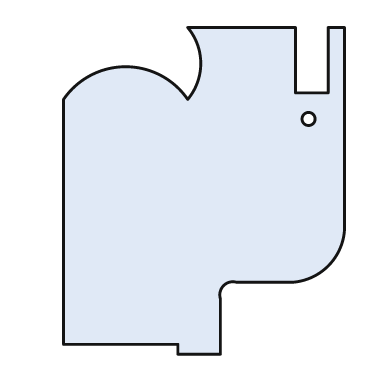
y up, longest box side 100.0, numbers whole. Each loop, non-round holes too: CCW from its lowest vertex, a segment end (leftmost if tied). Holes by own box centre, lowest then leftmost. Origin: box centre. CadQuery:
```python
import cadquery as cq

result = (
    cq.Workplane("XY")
    .moveTo(-8.0, -50.0)
    .lineTo(5.0, -50.0)
    .lineTo(5.0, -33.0)
    .threePointArc((6.0, -29.0), (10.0, -28.0))
    .lineTo(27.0, -28.0)
    .threePointArc((38.0, -23.0), (43.0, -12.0))
    .lineTo(43.0, 50.0)
    .lineTo(38.0, 50.0)
    .lineTo(38.0, 30.0)
    .lineTo(28.0, 30.0)
    .lineTo(28.0, 50.0)
    .lineTo(-5.0, 50.0)
    .threePointArc((-1.0, 39.0), (-5.0, 28.0))
    .threePointArc((-24.0, 38.0), (-43.0, 28.0))
    .lineTo(-43.0, -47.0)
    .lineTo(-8.0, -47.0)
    .close()
    .moveTo(32.0, 22.0)
    .circle(2.0)
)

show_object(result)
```